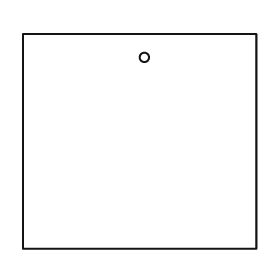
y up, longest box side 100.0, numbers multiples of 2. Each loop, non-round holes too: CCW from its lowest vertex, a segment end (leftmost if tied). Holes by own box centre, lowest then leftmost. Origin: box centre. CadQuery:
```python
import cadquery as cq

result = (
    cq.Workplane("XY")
    .moveTo(-50.0, -46.0)
    .lineTo(50.0, -46.0)
    .lineTo(50.0, 46.0)
    .lineTo(-50.0, 46.0)
    .close()
    .moveTo(2.0, 36.0)
    .circle(2.0)
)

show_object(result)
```